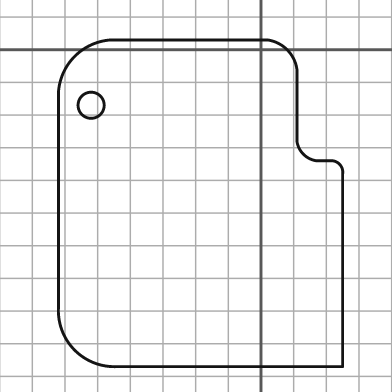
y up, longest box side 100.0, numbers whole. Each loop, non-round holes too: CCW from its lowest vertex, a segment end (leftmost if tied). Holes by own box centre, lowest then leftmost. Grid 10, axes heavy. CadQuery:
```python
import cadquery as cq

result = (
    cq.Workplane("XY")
    .moveTo(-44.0, -97.0)
    .lineTo(25.0, -97.0)
    .lineTo(25.0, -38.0)
    .threePointArc((24.0, -35.0), (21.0, -34.0))
    .lineTo(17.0, -34.0)
    .threePointArc((13.0, -32.0), (11.0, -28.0))
    .lineTo(11.0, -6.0)
    .threePointArc((8.0, 0.0), (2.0, 3.0))
    .lineTo(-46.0, 3.0)
    .threePointArc((-57.0, -2.0), (-62.0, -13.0))
    .lineTo(-62.0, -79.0)
    .threePointArc((-57.0, -92.0), (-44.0, -97.0))
    .close()
    .moveTo(-52.0, -17.0)
    .circle(4.0)
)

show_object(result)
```